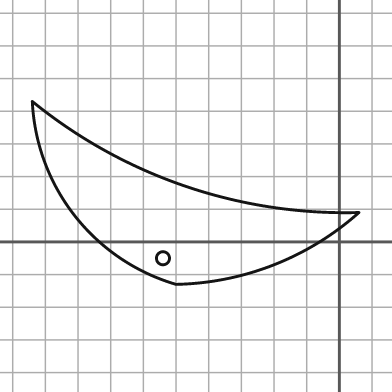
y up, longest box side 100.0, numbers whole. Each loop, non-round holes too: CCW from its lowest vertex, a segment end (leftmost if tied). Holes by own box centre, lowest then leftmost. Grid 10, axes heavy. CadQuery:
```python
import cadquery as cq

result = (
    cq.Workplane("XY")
    .moveTo(-50.0, -13.0)
    .threePointArc((-20.0, -7.0), (6.0, 9.0))
    .threePointArc((-47.0, 17.0), (-94.0, 43.0))
    .threePointArc((-81.0, 8.0), (-50.0, -13.0))
    .close()
    .moveTo(-54.0, -5.0)
    .circle(2.0)
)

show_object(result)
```